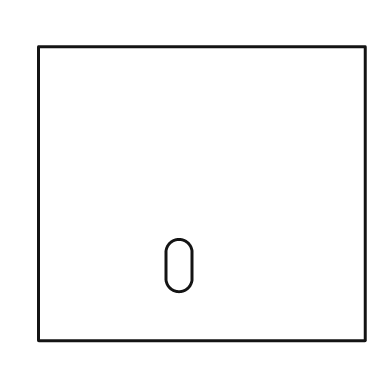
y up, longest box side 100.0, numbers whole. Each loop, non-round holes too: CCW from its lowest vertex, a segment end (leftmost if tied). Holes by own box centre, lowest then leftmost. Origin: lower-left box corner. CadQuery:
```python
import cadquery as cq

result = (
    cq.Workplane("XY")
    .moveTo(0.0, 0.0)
    .lineTo(100.0, 0.0)
    .lineTo(100.0, 90.0)
    .lineTo(0.0, 90.0)
    .close()
    .moveTo(39.0, 19.0)
    .threePointArc((43.0, 15.0), (47.0, 19.0))
    .lineTo(47.0, 27.0)
    .threePointArc((43.0, 31.0), (39.0, 27.0))
    .close()
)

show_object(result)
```